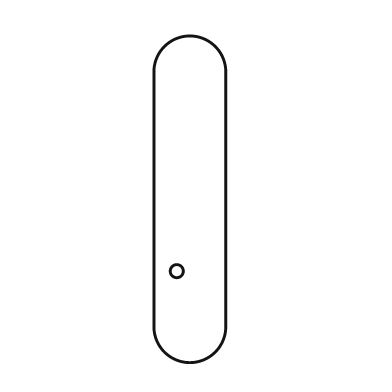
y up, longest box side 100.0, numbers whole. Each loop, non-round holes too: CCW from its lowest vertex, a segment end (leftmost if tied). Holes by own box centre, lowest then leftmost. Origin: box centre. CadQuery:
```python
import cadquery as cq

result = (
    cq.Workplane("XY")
    .moveTo(-11.0, -39.0)
    .threePointArc((0.0, -50.0), (11.0, -39.0))
    .lineTo(11.0, 39.0)
    .threePointArc((0.0, 50.0), (-11.0, 39.0))
    .close()
    .moveTo(-4.0, -22.0)
    .circle(2.0)
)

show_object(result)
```